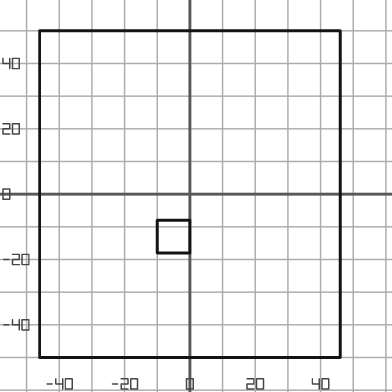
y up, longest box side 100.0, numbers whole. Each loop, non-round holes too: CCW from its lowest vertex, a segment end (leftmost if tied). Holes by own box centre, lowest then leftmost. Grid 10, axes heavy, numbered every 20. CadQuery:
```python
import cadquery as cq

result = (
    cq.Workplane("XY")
    .moveTo(-46.0, -50.0)
    .lineTo(46.0, -50.0)
    .lineTo(46.0, 50.0)
    .lineTo(-46.0, 50.0)
    .close()
    .moveTo(-10.0, -18.0)
    .lineTo(0.0, -18.0)
    .lineTo(0.0, -8.0)
    .lineTo(-10.0, -8.0)
    .close()
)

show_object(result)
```